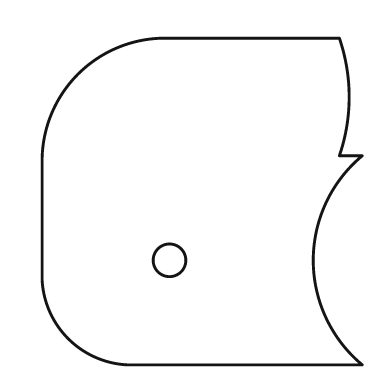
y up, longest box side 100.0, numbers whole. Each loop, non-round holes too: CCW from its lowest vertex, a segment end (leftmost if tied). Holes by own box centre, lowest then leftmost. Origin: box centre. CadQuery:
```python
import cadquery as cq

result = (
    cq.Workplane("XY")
    .moveTo(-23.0, -50.0)
    .lineTo(49.0, -50.0)
    .threePointArc((34.0, -18.0), (49.0, 14.0))
    .lineTo(42.0, 14.0)
    .threePointArc((45.0, 32.0), (42.0, 50.0))
    .lineTo(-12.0, 50.0)
    .threePointArc((-38.0, 39.0), (-49.0, 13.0))
    .lineTo(-49.0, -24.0)
    .threePointArc((-41.0, -42.0), (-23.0, -50.0))
    .close()
    .moveTo(-10.0, -18.0)
    .circle(5.0)
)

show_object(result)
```